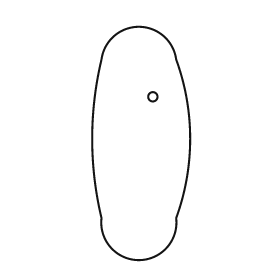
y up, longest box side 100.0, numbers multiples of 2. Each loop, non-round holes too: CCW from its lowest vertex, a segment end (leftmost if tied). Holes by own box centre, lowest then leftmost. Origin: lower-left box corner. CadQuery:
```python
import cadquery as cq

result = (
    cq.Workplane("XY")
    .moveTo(4.0, 18.0)
    .threePointArc((20.0, 0.0), (36.0, 18.0))
    .threePointArc((42.0, 52.0), (36.0, 86.0))
    .threePointArc((20.0, 100.0), (4.0, 86.0))
    .threePointArc((0.0, 52.0), (4.0, 18.0))
    .close()
    .moveTo(26.0, 70.0)
    .circle(2.0)
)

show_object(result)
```